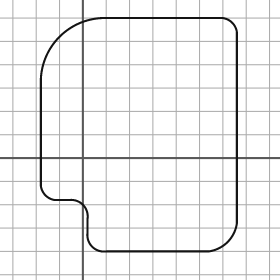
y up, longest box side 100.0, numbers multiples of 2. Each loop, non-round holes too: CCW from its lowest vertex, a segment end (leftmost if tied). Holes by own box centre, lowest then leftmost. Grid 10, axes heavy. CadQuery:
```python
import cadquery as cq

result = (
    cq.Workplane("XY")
    .moveTo(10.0, -40.0)
    .lineTo(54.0, -40.0)
    .threePointArc((62.0, -36.0), (66.0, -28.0))
    .lineTo(66.0, 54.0)
    .threePointArc((64.0, 58.0), (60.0, 60.0))
    .lineTo(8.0, 60.0)
    .threePointArc((-10.0, 52.0), (-18.0, 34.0))
    .lineTo(-18.0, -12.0)
    .threePointArc((-16.0, -16.0), (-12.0, -18.0))
    .lineTo(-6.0, -18.0)
    .threePointArc((0.0, -20.0), (2.0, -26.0))
    .lineTo(2.0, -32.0)
    .threePointArc((4.0, -38.0), (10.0, -40.0))
    .close()
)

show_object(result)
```